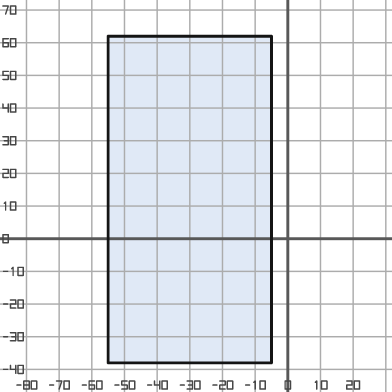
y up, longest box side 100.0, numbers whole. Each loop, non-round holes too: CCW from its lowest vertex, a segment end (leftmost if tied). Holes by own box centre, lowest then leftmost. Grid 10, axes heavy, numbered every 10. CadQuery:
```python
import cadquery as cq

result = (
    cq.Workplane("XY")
    .moveTo(-55.0, -38.0)
    .lineTo(-5.0, -38.0)
    .lineTo(-5.0, 62.0)
    .lineTo(-55.0, 62.0)
    .close()
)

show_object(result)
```